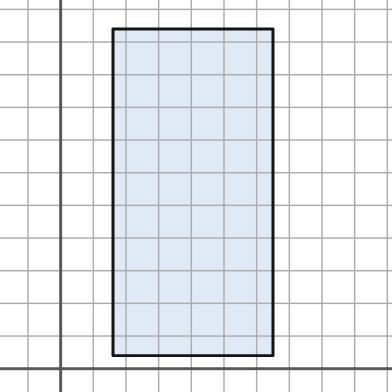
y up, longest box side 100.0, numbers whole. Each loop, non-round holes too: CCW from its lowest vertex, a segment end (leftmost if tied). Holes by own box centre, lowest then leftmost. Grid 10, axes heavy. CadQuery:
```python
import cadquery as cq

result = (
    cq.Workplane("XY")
    .moveTo(16.0, 4.0)
    .lineTo(65.0, 4.0)
    .lineTo(65.0, 104.0)
    .lineTo(16.0, 104.0)
    .close()
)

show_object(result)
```